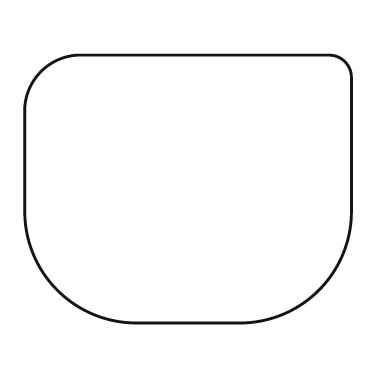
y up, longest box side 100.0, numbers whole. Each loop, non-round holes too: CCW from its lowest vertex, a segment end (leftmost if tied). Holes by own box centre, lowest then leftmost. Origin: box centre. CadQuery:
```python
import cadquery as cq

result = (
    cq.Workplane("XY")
    .moveTo(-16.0, -41.0)
    .lineTo(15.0, -41.0)
    .threePointArc((40.0, -31.0), (50.0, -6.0))
    .lineTo(50.0, 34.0)
    .threePointArc((48.0, 39.0), (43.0, 41.0))
    .lineTo(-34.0, 41.0)
    .threePointArc((-45.0, 36.0), (-50.0, 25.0))
    .lineTo(-50.0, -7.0)
    .threePointArc((-40.0, -31.0), (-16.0, -41.0))
    .close()
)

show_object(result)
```